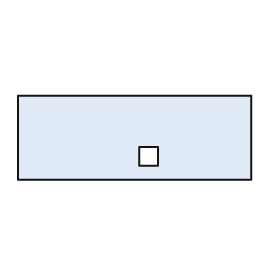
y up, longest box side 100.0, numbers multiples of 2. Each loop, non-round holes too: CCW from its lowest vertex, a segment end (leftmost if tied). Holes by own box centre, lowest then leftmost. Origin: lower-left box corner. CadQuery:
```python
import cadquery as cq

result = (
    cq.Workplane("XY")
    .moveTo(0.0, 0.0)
    .lineTo(100.0, 0.0)
    .lineTo(100.0, 36.0)
    .lineTo(0.0, 36.0)
    .close()
    .moveTo(52.0, 6.0)
    .lineTo(60.0, 6.0)
    .lineTo(60.0, 14.0)
    .lineTo(52.0, 14.0)
    .close()
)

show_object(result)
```